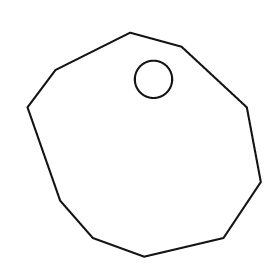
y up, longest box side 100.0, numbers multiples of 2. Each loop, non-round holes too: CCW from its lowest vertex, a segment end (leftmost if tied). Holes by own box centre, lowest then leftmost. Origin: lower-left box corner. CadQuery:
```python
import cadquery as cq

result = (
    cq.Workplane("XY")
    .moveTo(50.0, 0.0)
    .lineTo(84.0, 8.0)
    .lineTo(100.0, 32.0)
    .lineTo(94.0, 64.0)
    .lineTo(66.0, 90.0)
    .lineTo(44.0, 96.0)
    .lineTo(12.0, 80.0)
    .lineTo(0.0, 64.0)
    .lineTo(14.0, 24.0)
    .lineTo(28.0, 8.0)
    .close()
    .moveTo(54.0, 76.0)
    .circle(8.0)
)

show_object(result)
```